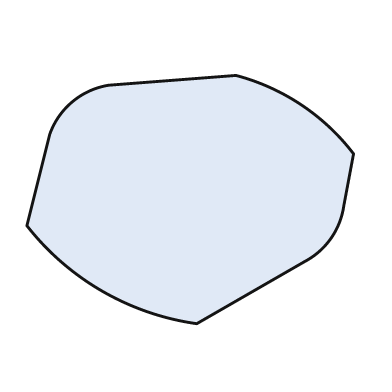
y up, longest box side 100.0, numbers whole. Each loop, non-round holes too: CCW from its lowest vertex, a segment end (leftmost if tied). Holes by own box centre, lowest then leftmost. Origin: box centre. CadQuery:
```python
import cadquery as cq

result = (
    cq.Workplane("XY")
    .moveTo(2.0, -38.0)
    .lineTo(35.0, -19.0)
    .threePointArc((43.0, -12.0), (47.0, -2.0))
    .lineTo(50.0, 14.0)
    .threePointArc((34.0, 29.0), (14.0, 38.0))
    .lineTo(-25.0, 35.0)
    .threePointArc((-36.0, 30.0), (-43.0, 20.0))
    .lineTo(-50.0, -8.0)
    .threePointArc((-27.0, -28.0), (2.0, -38.0))
    .close()
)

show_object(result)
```